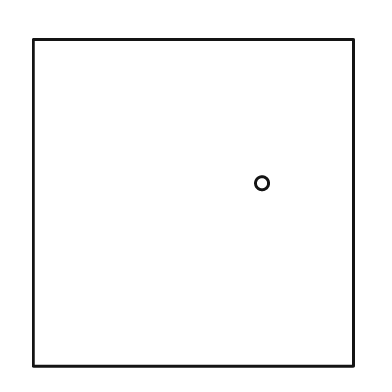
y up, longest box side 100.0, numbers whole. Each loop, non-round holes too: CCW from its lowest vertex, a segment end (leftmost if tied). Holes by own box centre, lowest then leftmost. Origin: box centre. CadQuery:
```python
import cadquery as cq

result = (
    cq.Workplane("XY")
    .moveTo(-49.0, -50.0)
    .lineTo(49.0, -50.0)
    .lineTo(49.0, 50.0)
    .lineTo(-49.0, 50.0)
    .close()
    .moveTo(21.0, 6.0)
    .circle(2.0)
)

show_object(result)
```